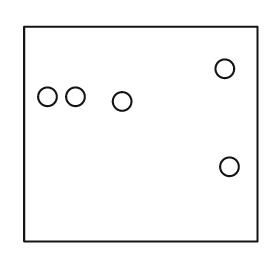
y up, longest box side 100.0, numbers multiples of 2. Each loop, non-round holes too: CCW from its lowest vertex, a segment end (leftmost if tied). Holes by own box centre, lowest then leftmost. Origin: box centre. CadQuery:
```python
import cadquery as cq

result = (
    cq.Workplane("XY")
    .moveTo(-50.0, -46.0)
    .lineTo(50.0, -46.0)
    .lineTo(50.0, 46.0)
    .lineTo(-50.0, 46.0)
    .close()
    .moveTo(38.0, -14.0)
    .circle(4.0)
    .moveTo(-8.0, 14.0)
    .circle(4.0)
    .moveTo(-40.0, 16.0)
    .circle(4.0)
    .moveTo(-28.0, 16.0)
    .circle(4.0)
    .moveTo(36.0, 28.0)
    .circle(4.0)
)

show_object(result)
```